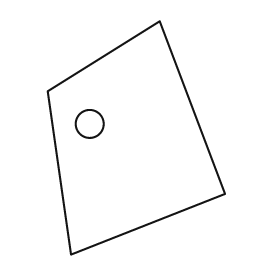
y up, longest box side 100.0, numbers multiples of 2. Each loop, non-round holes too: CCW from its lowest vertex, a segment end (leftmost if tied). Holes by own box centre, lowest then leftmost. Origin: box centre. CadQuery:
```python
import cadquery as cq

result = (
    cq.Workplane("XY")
    .moveTo(-28.0, -50.0)
    .lineTo(38.0, -24.0)
    .lineTo(10.0, 50.0)
    .lineTo(-38.0, 20.0)
    .close()
    .moveTo(-20.0, 6.0)
    .circle(6.0)
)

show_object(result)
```